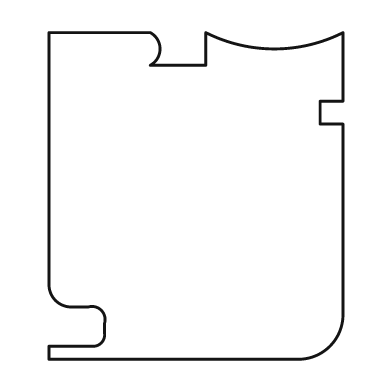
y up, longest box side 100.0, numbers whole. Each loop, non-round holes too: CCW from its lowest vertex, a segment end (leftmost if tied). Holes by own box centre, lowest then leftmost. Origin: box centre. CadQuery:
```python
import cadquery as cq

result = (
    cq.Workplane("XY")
    .moveTo(-45.0, -50.0)
    .lineTo(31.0, -50.0)
    .threePointArc((41.0, -46.0), (45.0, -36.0))
    .lineTo(45.0, 22.0)
    .lineTo(38.0, 22.0)
    .lineTo(38.0, 29.0)
    .lineTo(45.0, 29.0)
    .lineTo(45.0, 50.0)
    .threePointArc((24.0, 45.0), (3.0, 50.0))
    .lineTo(3.0, 40.0)
    .lineTo(-14.0, 40.0)
    .threePointArc((-11.0, 45.0), (-14.0, 50.0))
    .lineTo(-45.0, 50.0)
    .lineTo(-45.0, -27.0)
    .threePointArc((-43.0, -32.0), (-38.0, -34.0))
    .lineTo(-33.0, -34.0)
    .threePointArc((-29.0, -35.0), (-28.0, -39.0))
    .lineTo(-28.0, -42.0)
    .threePointArc((-29.0, -45.0), (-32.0, -46.0))
    .lineTo(-45.0, -46.0)
    .close()
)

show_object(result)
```